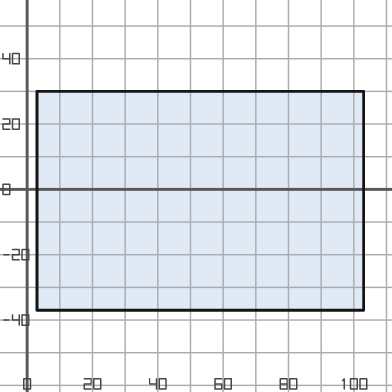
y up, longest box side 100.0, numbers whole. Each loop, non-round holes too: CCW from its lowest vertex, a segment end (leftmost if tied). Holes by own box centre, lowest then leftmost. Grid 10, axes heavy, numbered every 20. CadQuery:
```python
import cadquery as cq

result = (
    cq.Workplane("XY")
    .moveTo(3.0, -37.0)
    .lineTo(103.0, -37.0)
    .lineTo(103.0, 30.0)
    .lineTo(3.0, 30.0)
    .close()
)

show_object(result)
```